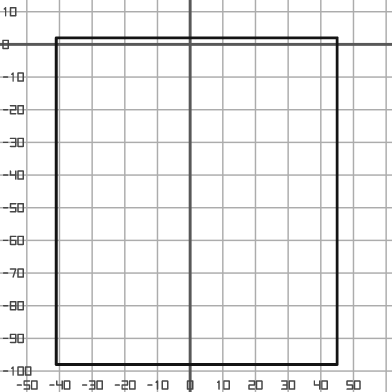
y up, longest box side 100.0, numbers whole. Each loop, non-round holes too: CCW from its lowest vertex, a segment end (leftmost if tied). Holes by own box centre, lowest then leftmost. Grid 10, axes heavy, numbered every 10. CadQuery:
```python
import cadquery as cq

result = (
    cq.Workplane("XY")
    .moveTo(-41.0, -98.0)
    .lineTo(45.0, -98.0)
    .lineTo(45.0, 2.0)
    .lineTo(-41.0, 2.0)
    .close()
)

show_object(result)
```